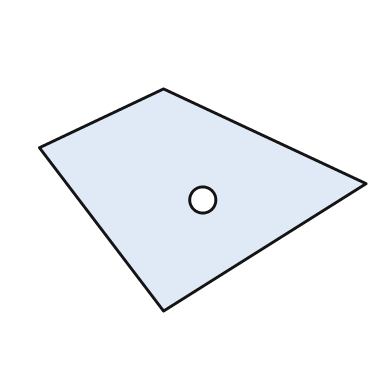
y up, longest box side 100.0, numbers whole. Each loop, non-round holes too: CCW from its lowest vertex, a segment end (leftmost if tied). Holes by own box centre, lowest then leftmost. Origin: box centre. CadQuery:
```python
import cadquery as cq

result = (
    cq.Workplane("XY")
    .moveTo(-12.0, -34.0)
    .lineTo(50.0, 5.0)
    .lineTo(-12.0, 34.0)
    .lineTo(-50.0, 16.0)
    .close()
    .moveTo(0.0, 0.0)
    .circle(4.0)
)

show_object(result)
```